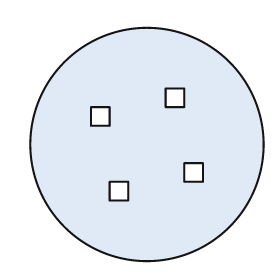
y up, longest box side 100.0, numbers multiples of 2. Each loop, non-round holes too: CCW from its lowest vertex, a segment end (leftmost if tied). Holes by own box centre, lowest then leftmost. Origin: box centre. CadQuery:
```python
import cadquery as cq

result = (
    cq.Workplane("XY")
    .moveTo(0.0, 0.0)
    .circle(50.0)
    .moveTo(-16.0, -24.0)
    .lineTo(-8.0, -24.0)
    .lineTo(-8.0, -16.0)
    .lineTo(-16.0, -16.0)
    .close()
    .moveTo(16.0, -16.0)
    .lineTo(24.0, -16.0)
    .lineTo(24.0, -8.0)
    .lineTo(16.0, -8.0)
    .close()
    .moveTo(-24.0, 8.0)
    .lineTo(-16.0, 8.0)
    .lineTo(-16.0, 16.0)
    .lineTo(-24.0, 16.0)
    .close()
    .moveTo(8.0, 16.0)
    .lineTo(16.0, 16.0)
    .lineTo(16.0, 24.0)
    .lineTo(8.0, 24.0)
    .close()
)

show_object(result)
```